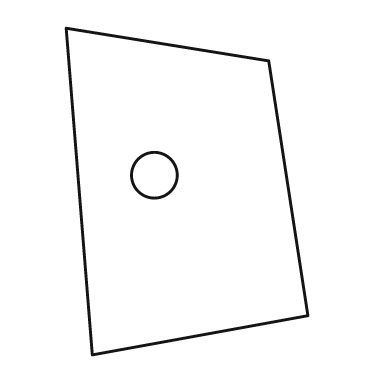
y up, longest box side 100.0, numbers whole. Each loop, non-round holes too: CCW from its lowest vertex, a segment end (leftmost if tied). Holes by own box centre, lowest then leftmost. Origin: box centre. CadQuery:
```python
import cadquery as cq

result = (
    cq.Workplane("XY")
    .moveTo(-29.0, -50.0)
    .lineTo(37.0, -38.0)
    .lineTo(25.0, 40.0)
    .lineTo(-37.0, 50.0)
    .close()
    .moveTo(-10.0, 5.0)
    .circle(7.0)
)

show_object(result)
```